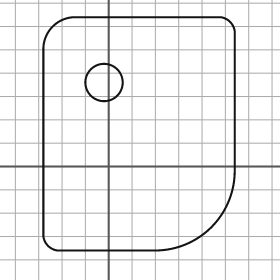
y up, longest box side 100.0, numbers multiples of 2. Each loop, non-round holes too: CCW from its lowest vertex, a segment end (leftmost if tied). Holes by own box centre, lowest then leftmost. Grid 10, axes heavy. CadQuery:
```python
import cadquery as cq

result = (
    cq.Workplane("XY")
    .moveTo(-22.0, -36.0)
    .lineTo(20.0, -36.0)
    .threePointArc((44.0, -26.0), (54.0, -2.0))
    .lineTo(54.0, 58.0)
    .threePointArc((52.0, 62.0), (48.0, 64.0))
    .lineTo(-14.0, 64.0)
    .threePointArc((-24.0, 60.0), (-28.0, 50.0))
    .lineTo(-28.0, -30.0)
    .threePointArc((-26.0, -34.0), (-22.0, -36.0))
    .close()
    .moveTo(-2.0, 36.0)
    .circle(8.0)
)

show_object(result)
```